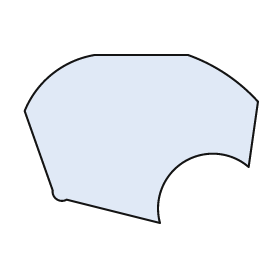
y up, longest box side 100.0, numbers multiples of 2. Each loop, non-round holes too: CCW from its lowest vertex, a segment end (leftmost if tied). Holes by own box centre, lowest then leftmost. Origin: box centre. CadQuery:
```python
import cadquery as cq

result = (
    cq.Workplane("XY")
    .moveTo(8.0, -36.0)
    .threePointArc((18.0, -10.0), (46.0, -12.0))
    .lineTo(50.0, 16.0)
    .threePointArc((36.0, 28.0), (20.0, 36.0))
    .lineTo(-20.0, 36.0)
    .threePointArc((-38.0, 28.0), (-50.0, 12.0))
    .lineTo(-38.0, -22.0)
    .threePointArc((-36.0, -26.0), (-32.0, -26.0))
    .close()
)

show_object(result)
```